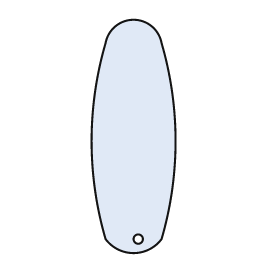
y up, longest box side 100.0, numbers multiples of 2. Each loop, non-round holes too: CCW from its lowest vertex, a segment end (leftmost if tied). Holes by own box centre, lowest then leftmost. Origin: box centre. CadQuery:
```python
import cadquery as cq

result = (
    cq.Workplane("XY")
    .moveTo(-12.0, -44.0)
    .threePointArc((0.0, -50.0), (12.0, -44.0))
    .threePointArc((18.0, -2.0), (12.0, 40.0))
    .threePointArc((0.0, 50.0), (-12.0, 40.0))
    .threePointArc((-18.0, -2.0), (-12.0, -44.0))
    .close()
    .moveTo(2.0, -44.0)
    .circle(2.0)
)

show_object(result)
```